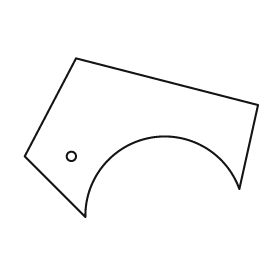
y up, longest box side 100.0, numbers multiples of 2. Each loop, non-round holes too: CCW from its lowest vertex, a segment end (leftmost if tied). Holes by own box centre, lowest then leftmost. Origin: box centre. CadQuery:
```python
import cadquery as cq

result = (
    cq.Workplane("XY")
    .moveTo(-24.0, -34.0)
    .threePointArc((4.0, 0.0), (42.0, -22.0))
    .lineTo(50.0, 14.0)
    .lineTo(-28.0, 34.0)
    .lineTo(-50.0, -8.0)
    .close()
    .moveTo(-30.0, -8.0)
    .circle(2.0)
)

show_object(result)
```